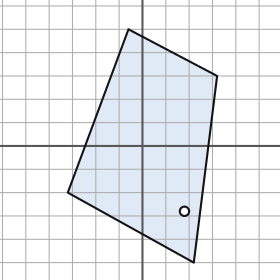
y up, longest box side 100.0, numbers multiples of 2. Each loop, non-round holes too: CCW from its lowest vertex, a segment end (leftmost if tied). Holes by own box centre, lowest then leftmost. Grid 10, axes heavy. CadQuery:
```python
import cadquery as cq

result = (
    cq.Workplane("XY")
    .moveTo(22.0, -50.0)
    .lineTo(32.0, 30.0)
    .lineTo(-6.0, 50.0)
    .lineTo(-32.0, -20.0)
    .close()
    .moveTo(18.0, -28.0)
    .circle(2.0)
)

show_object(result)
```